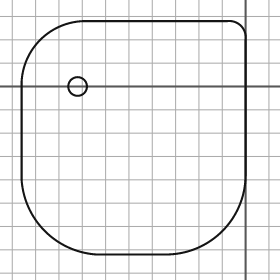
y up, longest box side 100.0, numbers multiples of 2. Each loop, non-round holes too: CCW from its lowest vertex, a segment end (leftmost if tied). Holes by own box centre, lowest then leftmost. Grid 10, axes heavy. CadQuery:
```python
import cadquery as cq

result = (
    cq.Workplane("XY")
    .moveTo(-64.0, -72.0)
    .lineTo(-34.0, -72.0)
    .threePointArc((-10.0, -62.0), (0.0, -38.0))
    .lineTo(0.0, 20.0)
    .threePointArc((-2.0, 26.0), (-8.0, 28.0))
    .lineTo(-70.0, 28.0)
    .threePointArc((-88.0, 20.0), (-96.0, 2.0))
    .lineTo(-96.0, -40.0)
    .threePointArc((-86.0, -62.0), (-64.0, -72.0))
    .close()
    .moveTo(-72.0, 0.0)
    .circle(4.0)
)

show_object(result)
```